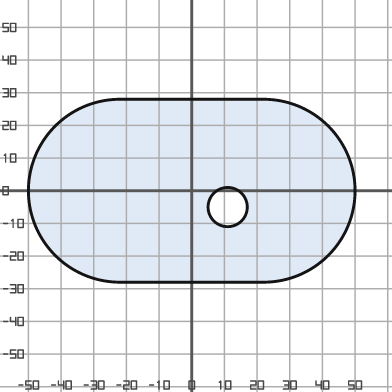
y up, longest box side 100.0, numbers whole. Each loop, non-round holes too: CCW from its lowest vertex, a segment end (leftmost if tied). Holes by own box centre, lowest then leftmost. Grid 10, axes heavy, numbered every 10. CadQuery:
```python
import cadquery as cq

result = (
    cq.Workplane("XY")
    .moveTo(-22.0, -28.0)
    .lineTo(22.0, -28.0)
    .threePointArc((50.0, 0.0), (22.0, 28.0))
    .lineTo(-22.0, 28.0)
    .threePointArc((-50.0, 0.0), (-22.0, -28.0))
    .close()
    .moveTo(11.0, -5.0)
    .circle(6.0)
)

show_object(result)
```